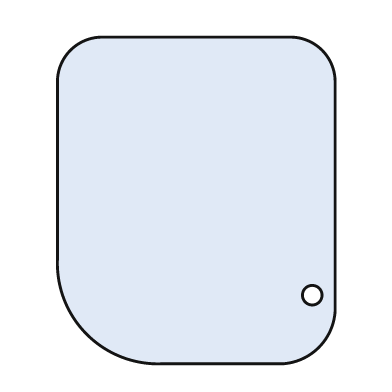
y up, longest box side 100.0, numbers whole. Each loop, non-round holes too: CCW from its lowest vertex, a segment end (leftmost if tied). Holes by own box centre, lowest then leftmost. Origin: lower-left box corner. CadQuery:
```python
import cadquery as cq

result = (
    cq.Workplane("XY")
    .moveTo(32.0, 0.0)
    .lineTo(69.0, 0.0)
    .threePointArc((80.0, 5.0), (85.0, 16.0))
    .lineTo(85.0, 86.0)
    .threePointArc((81.0, 96.0), (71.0, 100.0))
    .lineTo(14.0, 100.0)
    .threePointArc((4.0, 96.0), (0.0, 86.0))
    .lineTo(0.0, 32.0)
    .threePointArc((9.0, 9.0), (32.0, 0.0))
    .close()
    .moveTo(78.0, 21.0)
    .circle(3.0)
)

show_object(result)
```